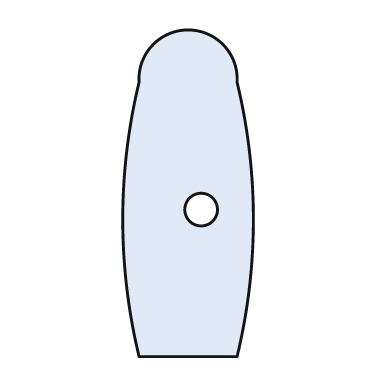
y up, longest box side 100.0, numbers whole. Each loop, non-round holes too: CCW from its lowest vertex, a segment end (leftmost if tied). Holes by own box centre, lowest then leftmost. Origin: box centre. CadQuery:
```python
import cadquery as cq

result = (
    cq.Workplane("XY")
    .moveTo(-15.0, -50.0)
    .lineTo(15.0, -50.0)
    .threePointArc((20.0, -8.0), (15.0, 34.0))
    .threePointArc((0.0, 50.0), (-15.0, 34.0))
    .threePointArc((-20.0, -8.0), (-15.0, -50.0))
    .close()
    .moveTo(4.0, -5.0)
    .circle(5.0)
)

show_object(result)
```